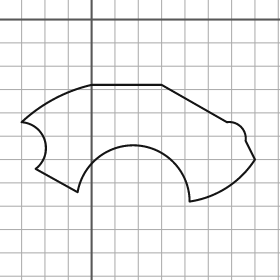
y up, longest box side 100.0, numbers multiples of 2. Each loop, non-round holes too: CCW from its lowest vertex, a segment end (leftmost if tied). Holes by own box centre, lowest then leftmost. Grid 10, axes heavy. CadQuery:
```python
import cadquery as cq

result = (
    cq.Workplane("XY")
    .moveTo(42.0, -78.0)
    .threePointArc((58.0, -72.0), (70.0, -60.0))
    .lineTo(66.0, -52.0)
    .threePointArc((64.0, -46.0), (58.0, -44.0))
    .lineTo(30.0, -28.0)
    .lineTo(0.0, -28.0)
    .threePointArc((-16.0, -34.0), (-30.0, -44.0))
    .threePointArc((-20.0, -52.0), (-24.0, -64.0))
    .lineTo(-6.0, -74.0)
    .threePointArc((20.0, -54.0), (42.0, -78.0))
    .close()
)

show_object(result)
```